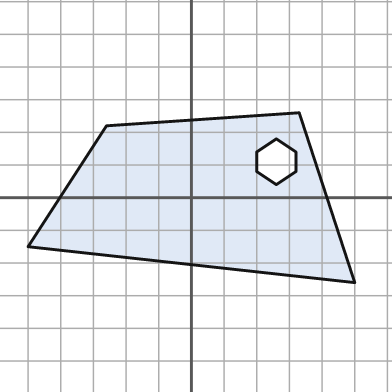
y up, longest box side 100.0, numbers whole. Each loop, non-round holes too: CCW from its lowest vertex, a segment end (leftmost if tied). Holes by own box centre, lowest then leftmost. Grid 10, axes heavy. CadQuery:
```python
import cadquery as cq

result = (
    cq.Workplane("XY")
    .moveTo(50.0, -26.0)
    .lineTo(33.0, 26.0)
    .lineTo(-26.0, 22.0)
    .lineTo(-50.0, -15.0)
    .close()
    .moveTo(26.0, 4.0)
    .lineTo(32.0, 8.0)
    .lineTo(32.0, 14.0)
    .lineTo(26.0, 18.0)
    .lineTo(20.0, 14.0)
    .lineTo(20.0, 8.0)
    .close()
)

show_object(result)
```